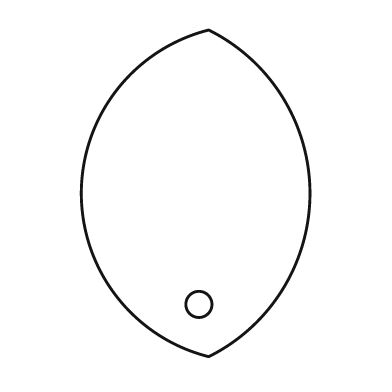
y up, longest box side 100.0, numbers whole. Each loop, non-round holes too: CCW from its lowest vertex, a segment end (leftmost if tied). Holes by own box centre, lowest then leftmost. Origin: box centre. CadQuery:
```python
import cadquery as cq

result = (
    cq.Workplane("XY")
    .moveTo(4.0, -50.0)
    .threePointArc((35.0, 0.0), (4.0, 50.0))
    .threePointArc((-35.0, 0.0), (4.0, -50.0))
    .close()
    .moveTo(1.0, -34.0)
    .circle(4.0)
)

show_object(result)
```